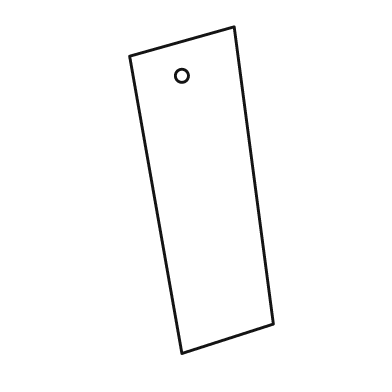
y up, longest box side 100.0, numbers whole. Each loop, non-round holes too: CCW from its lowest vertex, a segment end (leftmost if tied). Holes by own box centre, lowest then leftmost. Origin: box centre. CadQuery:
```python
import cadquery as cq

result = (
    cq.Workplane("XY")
    .moveTo(-6.0, -50.0)
    .lineTo(22.0, -41.0)
    .lineTo(10.0, 50.0)
    .lineTo(-22.0, 41.0)
    .close()
    .moveTo(-6.0, 35.0)
    .circle(2.0)
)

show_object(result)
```